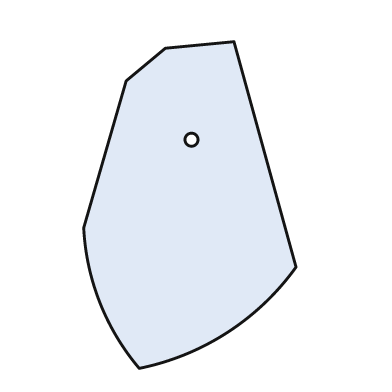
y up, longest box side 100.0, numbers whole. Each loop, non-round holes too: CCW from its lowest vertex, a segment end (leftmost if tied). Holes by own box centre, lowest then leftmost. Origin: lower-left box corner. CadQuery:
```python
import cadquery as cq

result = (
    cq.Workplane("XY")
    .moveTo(17.0, 0.0)
    .threePointArc((44.0, 11.0), (65.0, 31.0))
    .lineTo(46.0, 100.0)
    .lineTo(25.0, 98.0)
    .lineTo(13.0, 88.0)
    .lineTo(0.0, 43.0)
    .threePointArc((5.0, 20.0), (17.0, 0.0))
    .close()
    .moveTo(33.0, 70.0)
    .circle(2.0)
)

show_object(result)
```